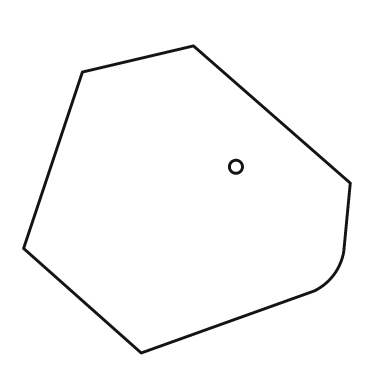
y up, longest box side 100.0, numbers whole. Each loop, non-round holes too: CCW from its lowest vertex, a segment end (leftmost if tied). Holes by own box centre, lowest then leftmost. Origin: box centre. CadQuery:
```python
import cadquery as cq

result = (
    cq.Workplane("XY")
    .moveTo(-14.0, -47.0)
    .lineTo(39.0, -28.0)
    .threePointArc((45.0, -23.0), (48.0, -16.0))
    .lineTo(50.0, 5.0)
    .lineTo(2.0, 47.0)
    .lineTo(-32.0, 39.0)
    .lineTo(-50.0, -15.0)
    .close()
    .moveTo(15.0, 10.0)
    .circle(2.0)
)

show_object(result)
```